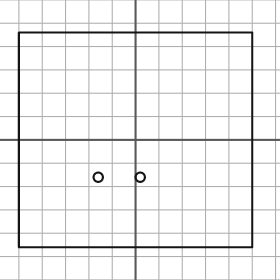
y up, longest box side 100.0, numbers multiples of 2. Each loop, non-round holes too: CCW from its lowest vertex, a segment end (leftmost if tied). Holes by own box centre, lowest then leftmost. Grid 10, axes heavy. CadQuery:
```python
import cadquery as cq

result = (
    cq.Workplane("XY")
    .moveTo(-50.0, -46.0)
    .lineTo(50.0, -46.0)
    .lineTo(50.0, 46.0)
    .lineTo(-50.0, 46.0)
    .close()
    .moveTo(-16.0, -16.0)
    .circle(2.0)
    .moveTo(2.0, -16.0)
    .circle(2.0)
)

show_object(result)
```